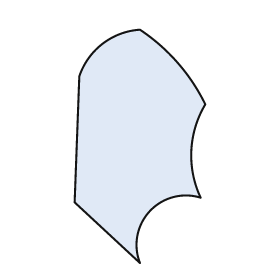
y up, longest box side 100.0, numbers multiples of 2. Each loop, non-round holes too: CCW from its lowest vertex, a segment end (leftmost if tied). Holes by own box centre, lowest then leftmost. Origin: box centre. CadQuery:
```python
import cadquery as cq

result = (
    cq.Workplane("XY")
    .moveTo(0.0, -50.0)
    .threePointArc((4.0, -28.0), (26.0, -22.0))
    .threePointArc((22.0, -2.0), (28.0, 18.0))
    .threePointArc((16.0, 36.0), (0.0, 50.0))
    .threePointArc((-16.0, 44.0), (-26.0, 30.0))
    .lineTo(-28.0, -24.0)
    .close()
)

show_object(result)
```